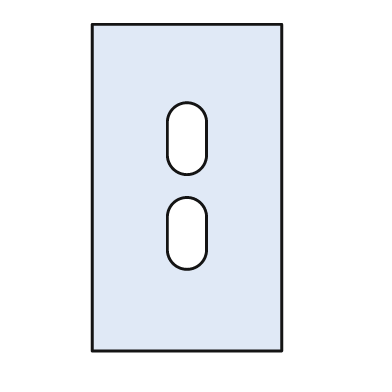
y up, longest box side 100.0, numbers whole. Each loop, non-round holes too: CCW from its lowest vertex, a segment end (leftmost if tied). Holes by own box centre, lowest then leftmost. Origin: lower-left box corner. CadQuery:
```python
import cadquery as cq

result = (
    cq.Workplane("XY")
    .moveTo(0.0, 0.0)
    .lineTo(58.0, 0.0)
    .lineTo(58.0, 100.0)
    .lineTo(0.0, 100.0)
    .close()
    .moveTo(23.0, 31.0)
    .threePointArc((29.0, 25.0), (35.0, 31.0))
    .lineTo(35.0, 41.0)
    .threePointArc((29.0, 47.0), (23.0, 41.0))
    .close()
    .moveTo(23.0, 60.0)
    .threePointArc((29.0, 54.0), (35.0, 60.0))
    .lineTo(35.0, 70.0)
    .threePointArc((29.0, 76.0), (23.0, 70.0))
    .close()
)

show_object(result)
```